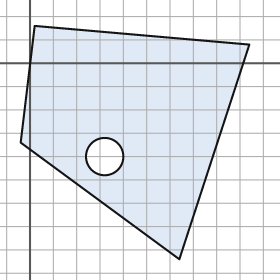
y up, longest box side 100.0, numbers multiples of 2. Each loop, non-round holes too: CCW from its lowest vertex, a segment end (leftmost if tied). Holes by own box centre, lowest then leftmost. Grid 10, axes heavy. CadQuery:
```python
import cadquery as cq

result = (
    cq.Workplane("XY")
    .moveTo(64.0, -84.0)
    .lineTo(94.0, 8.0)
    .lineTo(2.0, 16.0)
    .lineTo(-4.0, -34.0)
    .close()
    .moveTo(32.0, -40.0)
    .circle(8.0)
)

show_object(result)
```